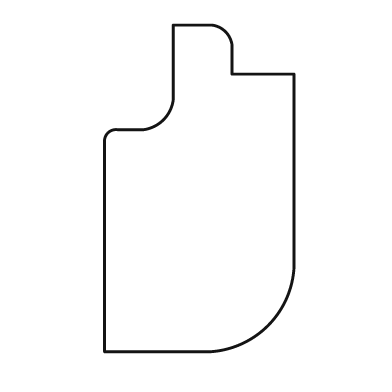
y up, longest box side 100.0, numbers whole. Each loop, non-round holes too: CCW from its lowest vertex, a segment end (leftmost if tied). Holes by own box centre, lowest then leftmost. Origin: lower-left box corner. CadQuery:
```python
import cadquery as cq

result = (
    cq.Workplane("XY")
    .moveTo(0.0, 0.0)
    .lineTo(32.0, 0.0)
    .threePointArc((50.0, 8.0), (58.0, 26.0))
    .lineTo(58.0, 85.0)
    .lineTo(39.0, 85.0)
    .lineTo(39.0, 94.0)
    .threePointArc((37.0, 98.0), (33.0, 100.0))
    .lineTo(21.0, 100.0)
    .lineTo(21.0, 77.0)
    .threePointArc((18.0, 71.0), (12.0, 68.0))
    .lineTo(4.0, 68.0)
    .threePointArc((1.0, 67.0), (0.0, 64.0))
    .close()
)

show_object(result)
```